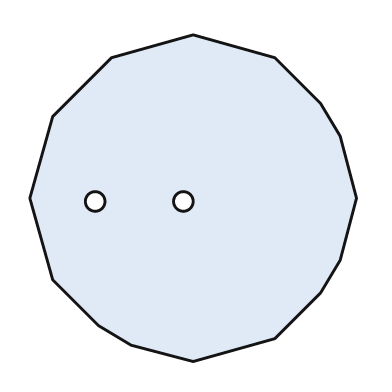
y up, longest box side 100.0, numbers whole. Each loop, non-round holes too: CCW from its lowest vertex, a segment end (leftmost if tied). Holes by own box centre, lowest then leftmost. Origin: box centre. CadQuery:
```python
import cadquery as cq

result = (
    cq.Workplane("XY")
    .moveTo(0.0, -50.0)
    .lineTo(25.0, -43.0)
    .lineTo(39.0, -29.0)
    .lineTo(45.0, -19.0)
    .lineTo(50.0, 0.0)
    .lineTo(45.0, 19.0)
    .lineTo(39.0, 29.0)
    .lineTo(25.0, 43.0)
    .lineTo(0.0, 50.0)
    .lineTo(-25.0, 43.0)
    .lineTo(-43.0, 25.0)
    .lineTo(-50.0, 0.0)
    .lineTo(-43.0, -25.0)
    .lineTo(-29.0, -39.0)
    .lineTo(-19.0, -45.0)
    .close()
    .moveTo(-30.0, -1.0)
    .circle(3.0)
    .moveTo(-3.0, -1.0)
    .circle(3.0)
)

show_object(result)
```